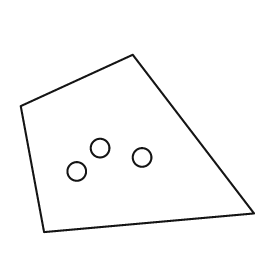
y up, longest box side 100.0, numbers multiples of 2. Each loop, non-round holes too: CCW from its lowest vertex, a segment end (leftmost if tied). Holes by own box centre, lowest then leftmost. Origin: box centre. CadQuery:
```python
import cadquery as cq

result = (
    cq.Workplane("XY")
    .moveTo(-40.0, -38.0)
    .lineTo(50.0, -30.0)
    .lineTo(-2.0, 38.0)
    .lineTo(-50.0, 16.0)
    .close()
    .moveTo(-26.0, -12.0)
    .circle(4.0)
    .moveTo(2.0, -6.0)
    .circle(4.0)
    .moveTo(-16.0, -2.0)
    .circle(4.0)
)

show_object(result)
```